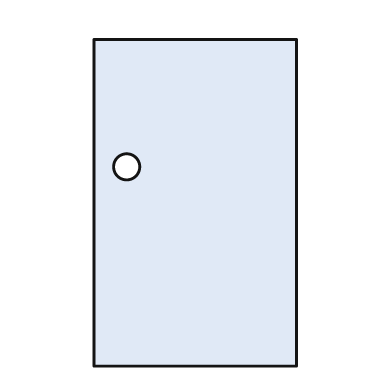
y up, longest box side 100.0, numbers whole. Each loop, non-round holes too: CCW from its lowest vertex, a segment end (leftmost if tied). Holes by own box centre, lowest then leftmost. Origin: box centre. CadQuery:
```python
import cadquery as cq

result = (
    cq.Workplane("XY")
    .moveTo(-31.0, -50.0)
    .lineTo(31.0, -50.0)
    .lineTo(31.0, 50.0)
    .lineTo(-31.0, 50.0)
    .close()
    .moveTo(-21.0, 11.0)
    .circle(4.0)
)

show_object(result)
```